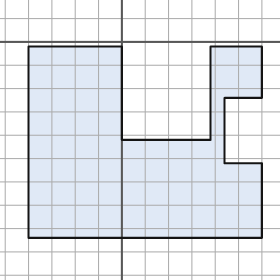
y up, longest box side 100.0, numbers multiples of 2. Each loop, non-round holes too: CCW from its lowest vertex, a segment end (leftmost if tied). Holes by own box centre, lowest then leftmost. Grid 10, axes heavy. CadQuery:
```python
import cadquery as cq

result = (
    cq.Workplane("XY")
    .moveTo(-40.0, -84.0)
    .lineTo(60.0, -84.0)
    .lineTo(60.0, -52.0)
    .lineTo(44.0, -52.0)
    .lineTo(44.0, -24.0)
    .lineTo(60.0, -24.0)
    .lineTo(60.0, -2.0)
    .lineTo(38.0, -2.0)
    .lineTo(38.0, -42.0)
    .lineTo(0.0, -42.0)
    .lineTo(0.0, -2.0)
    .lineTo(-40.0, -2.0)
    .close()
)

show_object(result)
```